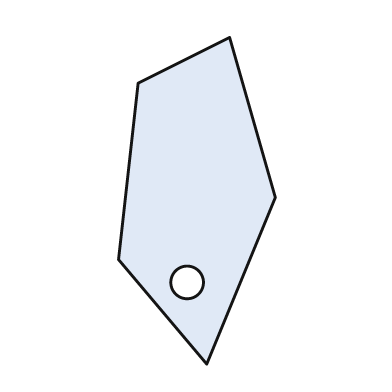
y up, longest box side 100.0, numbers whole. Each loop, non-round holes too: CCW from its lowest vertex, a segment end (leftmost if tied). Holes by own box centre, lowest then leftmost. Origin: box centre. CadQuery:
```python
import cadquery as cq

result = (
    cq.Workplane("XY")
    .moveTo(3.0, -50.0)
    .lineTo(24.0, 1.0)
    .lineTo(10.0, 50.0)
    .lineTo(-18.0, 36.0)
    .lineTo(-24.0, -18.0)
    .close()
    .moveTo(-3.0, -25.0)
    .circle(5.0)
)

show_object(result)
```